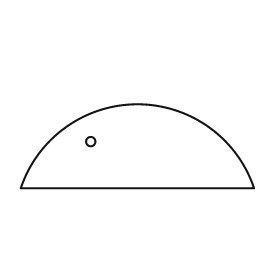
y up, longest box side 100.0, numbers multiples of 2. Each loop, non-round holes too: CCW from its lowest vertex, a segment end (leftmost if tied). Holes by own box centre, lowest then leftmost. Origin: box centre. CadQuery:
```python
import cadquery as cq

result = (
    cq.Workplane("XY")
    .moveTo(-50.0, -18.0)
    .lineTo(50.0, -18.0)
    .threePointArc((0.0, 18.0), (-50.0, -18.0))
    .close()
    .moveTo(-20.0, 2.0)
    .circle(2.0)
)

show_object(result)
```